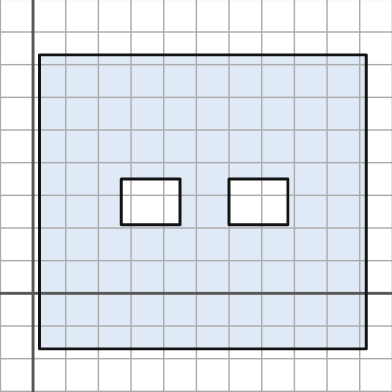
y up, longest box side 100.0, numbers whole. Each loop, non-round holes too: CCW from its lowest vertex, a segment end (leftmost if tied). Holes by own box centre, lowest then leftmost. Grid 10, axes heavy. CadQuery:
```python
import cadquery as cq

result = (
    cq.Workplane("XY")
    .moveTo(2.0, -17.0)
    .lineTo(102.0, -17.0)
    .lineTo(102.0, 73.0)
    .lineTo(2.0, 73.0)
    .close()
    .moveTo(27.0, 21.0)
    .lineTo(45.0, 21.0)
    .lineTo(45.0, 35.0)
    .lineTo(27.0, 35.0)
    .close()
    .moveTo(60.0, 21.0)
    .lineTo(78.0, 21.0)
    .lineTo(78.0, 35.0)
    .lineTo(60.0, 35.0)
    .close()
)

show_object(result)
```